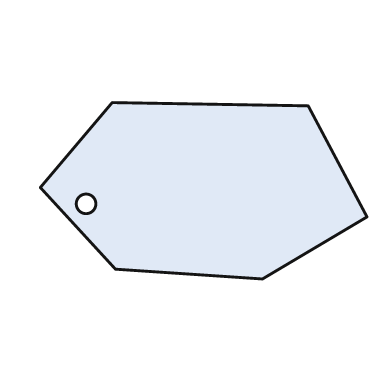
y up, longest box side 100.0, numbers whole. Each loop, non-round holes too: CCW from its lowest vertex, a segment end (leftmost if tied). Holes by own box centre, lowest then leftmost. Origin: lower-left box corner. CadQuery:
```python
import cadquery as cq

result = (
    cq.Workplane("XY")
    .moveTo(68.0, 0.0)
    .lineTo(100.0, 19.0)
    .lineTo(82.0, 53.0)
    .lineTo(22.0, 54.0)
    .lineTo(0.0, 28.0)
    .lineTo(23.0, 3.0)
    .close()
    .moveTo(14.0, 23.0)
    .circle(3.0)
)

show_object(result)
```